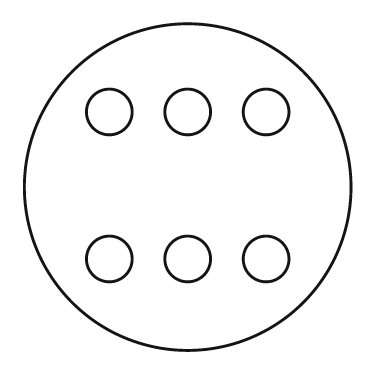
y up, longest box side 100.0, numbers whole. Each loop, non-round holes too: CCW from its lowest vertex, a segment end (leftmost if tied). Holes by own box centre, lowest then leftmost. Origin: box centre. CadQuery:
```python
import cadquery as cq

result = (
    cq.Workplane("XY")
    .moveTo(0.0, 0.0)
    .circle(50.0)
    .moveTo(-24.0, -22.0)
    .circle(7.0)
    .moveTo(0.0, -22.0)
    .circle(7.0)
    .moveTo(24.0, -22.0)
    .circle(7.0)
    .moveTo(-24.0, 23.0)
    .circle(7.0)
    .moveTo(0.0, 23.0)
    .circle(7.0)
    .moveTo(24.0, 23.0)
    .circle(7.0)
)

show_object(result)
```